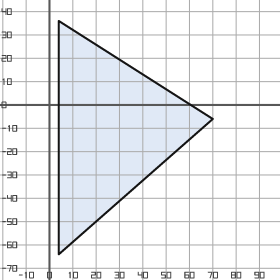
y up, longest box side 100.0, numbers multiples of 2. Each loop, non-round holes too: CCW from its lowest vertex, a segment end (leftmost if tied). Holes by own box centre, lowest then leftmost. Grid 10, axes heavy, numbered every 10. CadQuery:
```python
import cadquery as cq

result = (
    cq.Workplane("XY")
    .moveTo(4.0, -64.0)
    .lineTo(70.0, -6.0)
    .lineTo(4.0, 36.0)
    .close()
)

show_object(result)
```